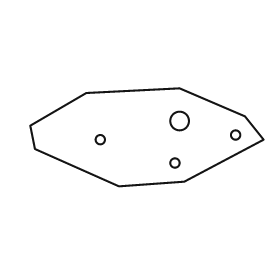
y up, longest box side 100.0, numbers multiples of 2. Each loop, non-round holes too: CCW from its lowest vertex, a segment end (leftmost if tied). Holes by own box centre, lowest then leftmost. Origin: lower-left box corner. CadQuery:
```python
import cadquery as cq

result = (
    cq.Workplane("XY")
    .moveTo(38.0, 0.0)
    .lineTo(66.0, 2.0)
    .lineTo(100.0, 20.0)
    .lineTo(92.0, 30.0)
    .lineTo(64.0, 42.0)
    .lineTo(24.0, 40.0)
    .lineTo(0.0, 26.0)
    .lineTo(2.0, 16.0)
    .close()
    .moveTo(62.0, 10.0)
    .circle(2.0)
    .moveTo(30.0, 20.0)
    .circle(2.0)
    .moveTo(88.0, 22.0)
    .circle(2.0)
    .moveTo(64.0, 28.0)
    .circle(4.0)
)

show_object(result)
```